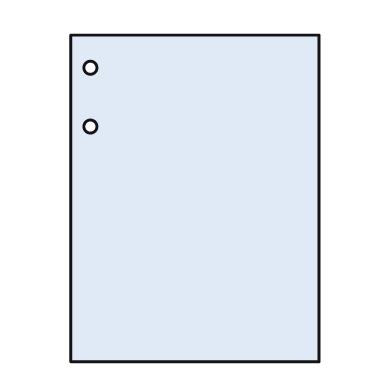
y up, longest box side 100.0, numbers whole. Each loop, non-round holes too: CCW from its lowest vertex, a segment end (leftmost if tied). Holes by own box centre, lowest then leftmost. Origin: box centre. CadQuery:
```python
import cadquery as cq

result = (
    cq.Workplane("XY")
    .moveTo(-38.0, -50.0)
    .lineTo(38.0, -50.0)
    .lineTo(38.0, 50.0)
    .lineTo(-38.0, 50.0)
    .close()
    .moveTo(-32.0, 22.0)
    .circle(2.0)
    .moveTo(-32.0, 40.0)
    .circle(2.0)
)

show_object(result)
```